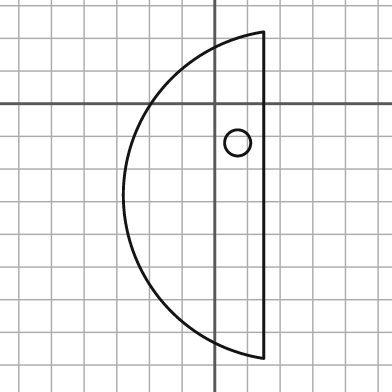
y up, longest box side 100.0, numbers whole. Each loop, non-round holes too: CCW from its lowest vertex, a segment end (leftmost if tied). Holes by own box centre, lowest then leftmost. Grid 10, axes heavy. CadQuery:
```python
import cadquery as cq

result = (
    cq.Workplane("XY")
    .moveTo(15.0, -78.0)
    .lineTo(15.0, 22.0)
    .threePointArc((-28.0, -28.0), (15.0, -78.0))
    .close()
    .moveTo(7.0, -12.0)
    .circle(4.0)
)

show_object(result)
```